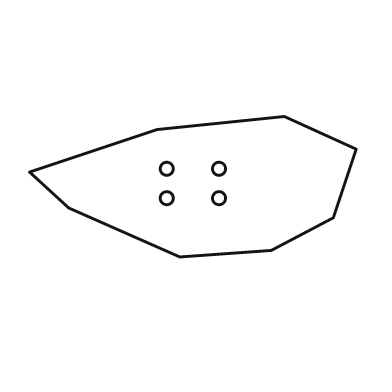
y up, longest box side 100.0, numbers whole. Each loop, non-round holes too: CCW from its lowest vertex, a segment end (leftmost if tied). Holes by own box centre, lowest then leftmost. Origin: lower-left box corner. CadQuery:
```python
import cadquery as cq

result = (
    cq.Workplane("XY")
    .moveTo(46.0, 0.0)
    .lineTo(74.0, 2.0)
    .lineTo(93.0, 12.0)
    .lineTo(100.0, 33.0)
    .lineTo(78.0, 43.0)
    .lineTo(39.0, 39.0)
    .lineTo(0.0, 26.0)
    .lineTo(12.0, 15.0)
    .close()
    .moveTo(42.0, 18.0)
    .circle(2.0)
    .moveTo(58.0, 18.0)
    .circle(2.0)
    .moveTo(42.0, 27.0)
    .circle(2.0)
    .moveTo(58.0, 27.0)
    .circle(2.0)
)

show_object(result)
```